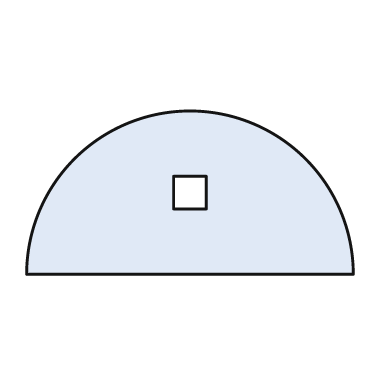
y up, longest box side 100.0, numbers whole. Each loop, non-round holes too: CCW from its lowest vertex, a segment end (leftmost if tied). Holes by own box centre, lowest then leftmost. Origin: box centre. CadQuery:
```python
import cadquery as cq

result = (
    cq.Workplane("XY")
    .moveTo(-50.0, -25.0)
    .lineTo(50.0, -25.0)
    .threePointArc((0.0, 25.0), (-50.0, -25.0))
    .close()
    .moveTo(-5.0, -5.0)
    .lineTo(5.0, -5.0)
    .lineTo(5.0, 5.0)
    .lineTo(-5.0, 5.0)
    .close()
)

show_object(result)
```